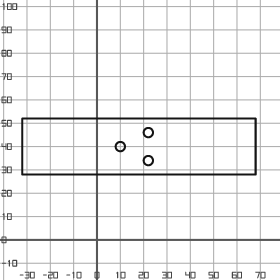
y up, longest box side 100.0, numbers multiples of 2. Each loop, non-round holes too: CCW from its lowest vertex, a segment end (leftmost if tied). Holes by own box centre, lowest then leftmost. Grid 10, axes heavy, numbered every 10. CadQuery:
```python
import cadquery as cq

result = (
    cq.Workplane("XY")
    .moveTo(-32.0, 28.0)
    .lineTo(68.0, 28.0)
    .lineTo(68.0, 52.0)
    .lineTo(-32.0, 52.0)
    .close()
    .moveTo(22.0, 34.0)
    .circle(2.0)
    .moveTo(10.0, 40.0)
    .circle(2.0)
    .moveTo(22.0, 46.0)
    .circle(2.0)
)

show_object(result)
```